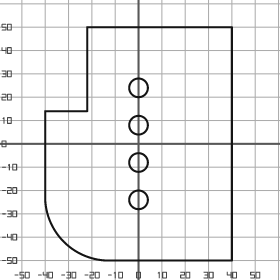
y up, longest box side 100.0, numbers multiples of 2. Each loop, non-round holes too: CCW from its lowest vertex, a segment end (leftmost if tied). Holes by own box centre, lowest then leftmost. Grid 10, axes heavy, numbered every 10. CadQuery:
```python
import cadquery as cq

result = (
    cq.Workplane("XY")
    .moveTo(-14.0, -50.0)
    .lineTo(40.0, -50.0)
    .lineTo(40.0, 50.0)
    .lineTo(-22.0, 50.0)
    .lineTo(-22.0, 14.0)
    .lineTo(-40.0, 14.0)
    .lineTo(-40.0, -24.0)
    .threePointArc((-32.0, -42.0), (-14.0, -50.0))
    .close()
    .moveTo(0.0, -24.0)
    .circle(4.0)
    .moveTo(0.0, -8.0)
    .circle(4.0)
    .moveTo(0.0, 8.0)
    .circle(4.0)
    .moveTo(0.0, 24.0)
    .circle(4.0)
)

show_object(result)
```